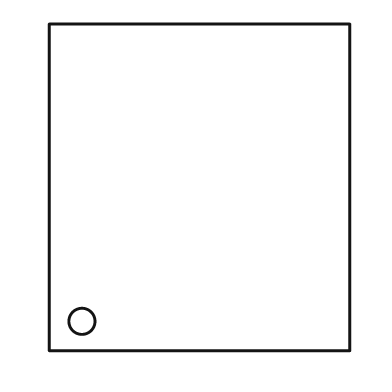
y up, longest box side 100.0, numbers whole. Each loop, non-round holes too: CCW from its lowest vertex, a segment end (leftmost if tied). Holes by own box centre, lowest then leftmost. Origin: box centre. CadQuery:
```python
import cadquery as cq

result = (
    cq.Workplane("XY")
    .moveTo(-46.0, -50.0)
    .lineTo(46.0, -50.0)
    .lineTo(46.0, 50.0)
    .lineTo(-46.0, 50.0)
    .close()
    .moveTo(-36.0, -41.0)
    .circle(4.0)
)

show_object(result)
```